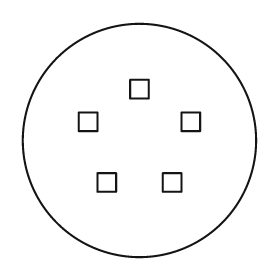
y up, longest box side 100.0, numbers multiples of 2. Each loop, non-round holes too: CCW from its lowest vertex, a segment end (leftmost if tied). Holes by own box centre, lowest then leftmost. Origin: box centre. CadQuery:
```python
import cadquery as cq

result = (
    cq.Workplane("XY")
    .moveTo(0.0, 0.0)
    .circle(50.0)
    .moveTo(-18.0, -22.0)
    .lineTo(-10.0, -22.0)
    .lineTo(-10.0, -14.0)
    .lineTo(-18.0, -14.0)
    .close()
    .moveTo(10.0, -22.0)
    .lineTo(18.0, -22.0)
    .lineTo(18.0, -14.0)
    .lineTo(10.0, -14.0)
    .close()
    .moveTo(-26.0, 4.0)
    .lineTo(-18.0, 4.0)
    .lineTo(-18.0, 12.0)
    .lineTo(-26.0, 12.0)
    .close()
    .moveTo(18.0, 4.0)
    .lineTo(26.0, 4.0)
    .lineTo(26.0, 12.0)
    .lineTo(18.0, 12.0)
    .close()
    .moveTo(-4.0, 18.0)
    .lineTo(4.0, 18.0)
    .lineTo(4.0, 26.0)
    .lineTo(-4.0, 26.0)
    .close()
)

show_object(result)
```